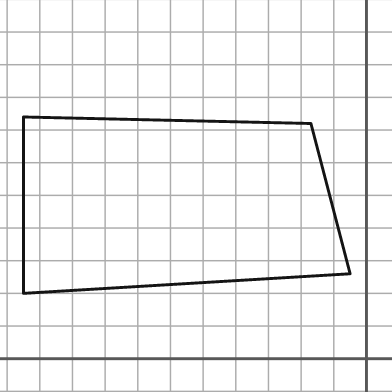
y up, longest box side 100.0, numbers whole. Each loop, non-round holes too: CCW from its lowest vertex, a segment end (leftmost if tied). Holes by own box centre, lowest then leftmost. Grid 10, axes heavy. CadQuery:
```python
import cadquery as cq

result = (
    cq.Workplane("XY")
    .moveTo(-105.0, 20.0)
    .lineTo(-5.0, 26.0)
    .lineTo(-17.0, 72.0)
    .lineTo(-105.0, 74.0)
    .close()
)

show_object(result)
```